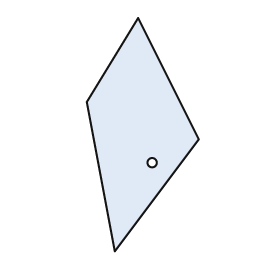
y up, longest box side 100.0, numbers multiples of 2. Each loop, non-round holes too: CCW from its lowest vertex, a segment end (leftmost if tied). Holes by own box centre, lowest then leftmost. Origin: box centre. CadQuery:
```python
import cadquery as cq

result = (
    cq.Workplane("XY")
    .moveTo(-12.0, -50.0)
    .lineTo(24.0, -2.0)
    .lineTo(-2.0, 50.0)
    .lineTo(-24.0, 14.0)
    .close()
    .moveTo(4.0, -12.0)
    .circle(2.0)
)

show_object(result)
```